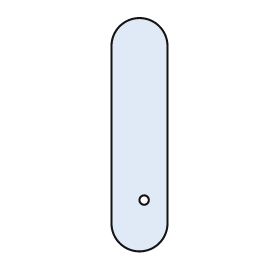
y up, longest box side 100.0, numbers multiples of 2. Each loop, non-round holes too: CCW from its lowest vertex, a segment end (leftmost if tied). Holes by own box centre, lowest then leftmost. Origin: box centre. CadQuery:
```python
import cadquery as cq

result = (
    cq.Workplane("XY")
    .moveTo(-12.0, -38.0)
    .threePointArc((0.0, -50.0), (12.0, -38.0))
    .lineTo(12.0, 38.0)
    .threePointArc((0.0, 50.0), (-12.0, 38.0))
    .close()
    .moveTo(2.0, -28.0)
    .circle(2.0)
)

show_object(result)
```